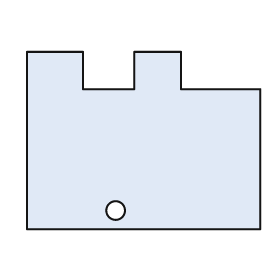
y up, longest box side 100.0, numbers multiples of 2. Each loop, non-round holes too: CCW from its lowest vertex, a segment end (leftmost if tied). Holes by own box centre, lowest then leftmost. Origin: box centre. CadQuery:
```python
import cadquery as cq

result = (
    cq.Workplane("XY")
    .moveTo(-50.0, -38.0)
    .lineTo(50.0, -38.0)
    .lineTo(50.0, 22.0)
    .lineTo(16.0, 22.0)
    .lineTo(16.0, 38.0)
    .lineTo(-4.0, 38.0)
    .lineTo(-4.0, 22.0)
    .lineTo(-26.0, 22.0)
    .lineTo(-26.0, 38.0)
    .lineTo(-50.0, 38.0)
    .close()
    .moveTo(-12.0, -30.0)
    .circle(4.0)
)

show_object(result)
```